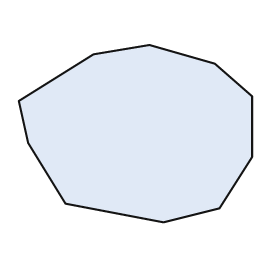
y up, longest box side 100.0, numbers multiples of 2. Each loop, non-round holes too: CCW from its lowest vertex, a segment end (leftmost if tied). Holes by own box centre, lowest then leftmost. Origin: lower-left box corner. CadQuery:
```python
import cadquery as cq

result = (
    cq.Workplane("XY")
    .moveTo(62.0, 0.0)
    .lineTo(86.0, 6.0)
    .lineTo(100.0, 28.0)
    .lineTo(100.0, 54.0)
    .lineTo(84.0, 68.0)
    .lineTo(56.0, 76.0)
    .lineTo(32.0, 72.0)
    .lineTo(0.0, 52.0)
    .lineTo(4.0, 34.0)
    .lineTo(20.0, 8.0)
    .close()
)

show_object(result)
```